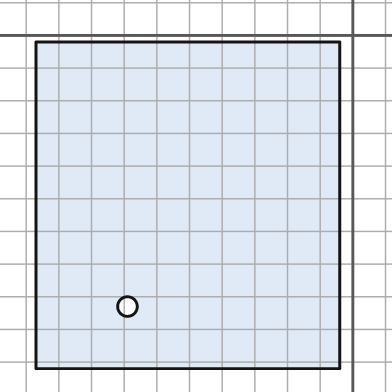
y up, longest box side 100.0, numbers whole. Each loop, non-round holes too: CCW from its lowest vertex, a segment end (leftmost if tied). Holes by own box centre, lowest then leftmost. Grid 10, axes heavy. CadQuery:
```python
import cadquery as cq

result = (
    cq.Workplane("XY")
    .moveTo(-97.0, -102.0)
    .lineTo(-4.0, -102.0)
    .lineTo(-4.0, -2.0)
    .lineTo(-97.0, -2.0)
    .close()
    .moveTo(-69.0, -83.0)
    .circle(3.0)
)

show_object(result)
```